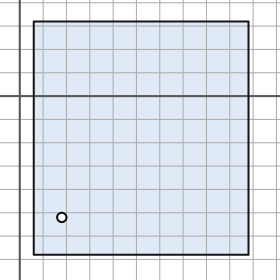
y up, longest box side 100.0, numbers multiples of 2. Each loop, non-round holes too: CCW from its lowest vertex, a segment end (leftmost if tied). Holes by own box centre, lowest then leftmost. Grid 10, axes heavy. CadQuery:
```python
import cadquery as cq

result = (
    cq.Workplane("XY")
    .moveTo(6.0, -68.0)
    .lineTo(98.0, -68.0)
    .lineTo(98.0, 32.0)
    .lineTo(6.0, 32.0)
    .close()
    .moveTo(18.0, -52.0)
    .circle(2.0)
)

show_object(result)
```